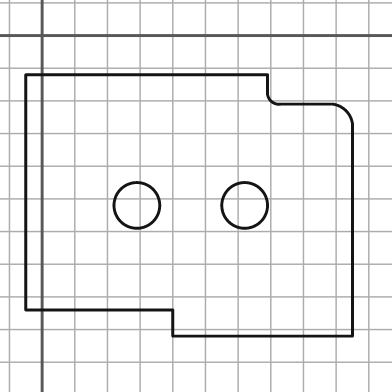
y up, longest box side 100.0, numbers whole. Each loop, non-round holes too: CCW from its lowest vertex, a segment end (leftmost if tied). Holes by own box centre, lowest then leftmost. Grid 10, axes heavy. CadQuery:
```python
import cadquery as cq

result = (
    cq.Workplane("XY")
    .moveTo(40.0, -92.0)
    .lineTo(95.0, -92.0)
    .lineTo(95.0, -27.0)
    .threePointArc((93.0, -23.0), (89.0, -21.0))
    .lineTo(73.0, -21.0)
    .threePointArc((70.0, -20.0), (69.0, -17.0))
    .lineTo(69.0, -12.0)
    .lineTo(-5.0, -12.0)
    .lineTo(-5.0, -84.0)
    .lineTo(40.0, -84.0)
    .close()
    .moveTo(29.0, -52.0)
    .circle(7.0)
    .moveTo(62.0, -52.0)
    .circle(7.0)
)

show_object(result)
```